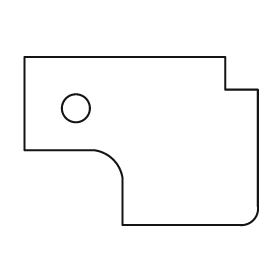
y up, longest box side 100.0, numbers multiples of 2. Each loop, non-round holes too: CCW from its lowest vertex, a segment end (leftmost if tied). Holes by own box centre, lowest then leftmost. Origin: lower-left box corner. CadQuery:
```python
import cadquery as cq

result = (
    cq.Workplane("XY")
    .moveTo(42.0, 0.0)
    .lineTo(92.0, 0.0)
    .threePointArc((98.0, 2.0), (100.0, 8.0))
    .lineTo(100.0, 58.0)
    .lineTo(86.0, 58.0)
    .lineTo(86.0, 72.0)
    .lineTo(0.0, 72.0)
    .lineTo(0.0, 32.0)
    .lineTo(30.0, 32.0)
    .threePointArc((38.0, 28.0), (42.0, 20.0))
    .close()
    .moveTo(22.0, 50.0)
    .circle(6.0)
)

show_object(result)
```